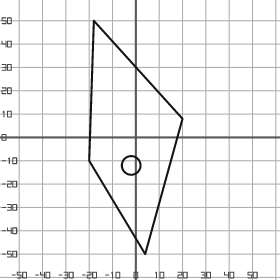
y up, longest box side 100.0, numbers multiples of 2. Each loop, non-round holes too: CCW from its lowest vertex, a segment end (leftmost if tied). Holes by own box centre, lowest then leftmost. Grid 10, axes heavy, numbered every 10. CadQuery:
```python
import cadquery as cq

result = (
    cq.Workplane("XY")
    .moveTo(4.0, -50.0)
    .lineTo(20.0, 8.0)
    .lineTo(-18.0, 50.0)
    .lineTo(-20.0, -10.0)
    .close()
    .moveTo(-2.0, -12.0)
    .circle(4.0)
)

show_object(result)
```